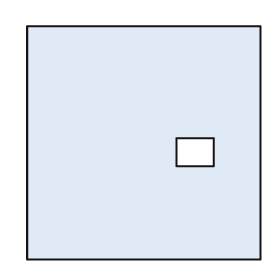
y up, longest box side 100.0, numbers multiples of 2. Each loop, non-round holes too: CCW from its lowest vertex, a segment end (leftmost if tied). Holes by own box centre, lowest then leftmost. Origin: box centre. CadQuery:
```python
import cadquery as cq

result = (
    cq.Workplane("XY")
    .moveTo(-50.0, -50.0)
    .lineTo(50.0, -50.0)
    .lineTo(50.0, 50.0)
    .lineTo(-50.0, 50.0)
    .close()
    .moveTo(14.0, -10.0)
    .lineTo(30.0, -10.0)
    .lineTo(30.0, 2.0)
    .lineTo(14.0, 2.0)
    .close()
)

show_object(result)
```